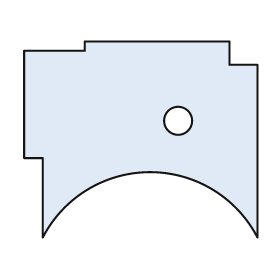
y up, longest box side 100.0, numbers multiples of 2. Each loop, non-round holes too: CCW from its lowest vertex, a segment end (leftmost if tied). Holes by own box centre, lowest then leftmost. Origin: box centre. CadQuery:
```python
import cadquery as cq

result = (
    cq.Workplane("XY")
    .moveTo(-42.0, -42.0)
    .threePointArc((4.0, -14.0), (50.0, -42.0))
    .lineTo(50.0, 32.0)
    .lineTo(38.0, 32.0)
    .lineTo(38.0, 42.0)
    .lineTo(-24.0, 42.0)
    .lineTo(-24.0, 38.0)
    .lineTo(-50.0, 38.0)
    .lineTo(-50.0, -8.0)
    .lineTo(-42.0, -8.0)
    .close()
    .moveTo(16.0, 8.0)
    .circle(6.0)
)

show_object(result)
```